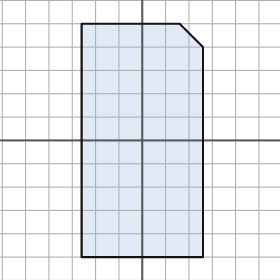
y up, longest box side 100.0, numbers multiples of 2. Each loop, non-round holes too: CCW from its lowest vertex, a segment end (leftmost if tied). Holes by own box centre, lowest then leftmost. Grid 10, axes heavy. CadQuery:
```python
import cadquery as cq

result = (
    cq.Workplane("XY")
    .moveTo(-26.0, -50.0)
    .lineTo(26.0, -50.0)
    .lineTo(26.0, 40.0)
    .lineTo(16.0, 50.0)
    .lineTo(-26.0, 50.0)
    .close()
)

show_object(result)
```